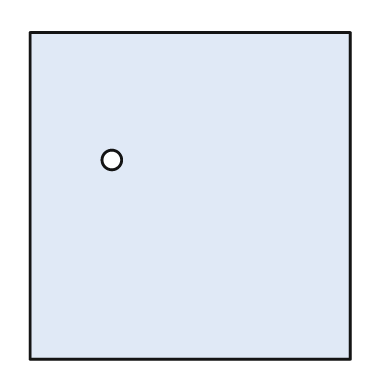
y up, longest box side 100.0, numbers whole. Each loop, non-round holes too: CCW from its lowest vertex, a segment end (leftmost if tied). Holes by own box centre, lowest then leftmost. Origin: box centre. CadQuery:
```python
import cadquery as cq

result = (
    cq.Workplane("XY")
    .moveTo(-49.0, -50.0)
    .lineTo(49.0, -50.0)
    .lineTo(49.0, 50.0)
    .lineTo(-49.0, 50.0)
    .close()
    .moveTo(-24.0, 11.0)
    .circle(3.0)
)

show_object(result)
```